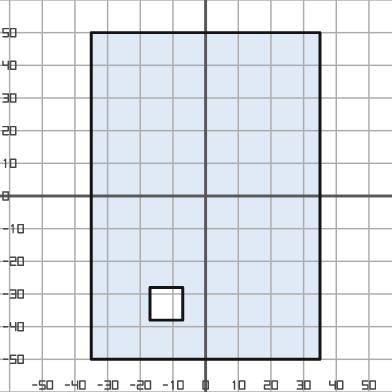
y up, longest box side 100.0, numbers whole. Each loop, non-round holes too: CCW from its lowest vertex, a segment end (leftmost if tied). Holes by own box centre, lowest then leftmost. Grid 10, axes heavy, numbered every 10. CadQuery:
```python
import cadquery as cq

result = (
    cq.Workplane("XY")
    .moveTo(-35.0, -50.0)
    .lineTo(35.0, -50.0)
    .lineTo(35.0, 50.0)
    .lineTo(-35.0, 50.0)
    .close()
    .moveTo(-17.0, -38.0)
    .lineTo(-7.0, -38.0)
    .lineTo(-7.0, -28.0)
    .lineTo(-17.0, -28.0)
    .close()
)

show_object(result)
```